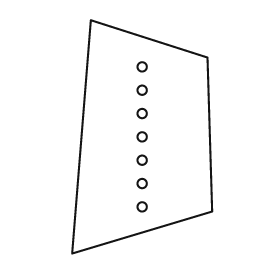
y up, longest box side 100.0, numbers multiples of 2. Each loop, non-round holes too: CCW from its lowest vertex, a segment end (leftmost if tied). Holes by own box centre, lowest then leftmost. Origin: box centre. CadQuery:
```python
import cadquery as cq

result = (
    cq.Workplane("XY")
    .moveTo(-30.0, -50.0)
    .lineTo(30.0, -32.0)
    .lineTo(28.0, 34.0)
    .lineTo(-22.0, 50.0)
    .close()
    .moveTo(0.0, -30.0)
    .circle(2.0)
    .moveTo(0.0, -20.0)
    .circle(2.0)
    .moveTo(0.0, -10.0)
    .circle(2.0)
    .moveTo(0.0, 0.0)
    .circle(2.0)
    .moveTo(0.0, 10.0)
    .circle(2.0)
    .moveTo(0.0, 20.0)
    .circle(2.0)
    .moveTo(0.0, 30.0)
    .circle(2.0)
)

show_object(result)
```